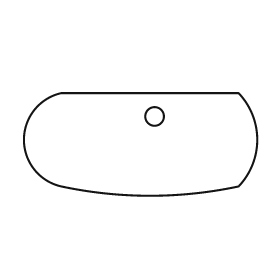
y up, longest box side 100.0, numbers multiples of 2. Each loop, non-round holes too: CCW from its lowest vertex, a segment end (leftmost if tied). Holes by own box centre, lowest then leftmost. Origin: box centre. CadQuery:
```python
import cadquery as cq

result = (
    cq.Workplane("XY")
    .moveTo(-34.0, -18.0)
    .threePointArc((4.0, -22.0), (42.0, -18.0))
    .threePointArc((50.0, 2.0), (42.0, 22.0))
    .lineTo(-34.0, 22.0)
    .threePointArc((-50.0, 2.0), (-34.0, -18.0))
    .close()
    .moveTo(6.0, 12.0)
    .circle(4.0)
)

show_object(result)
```